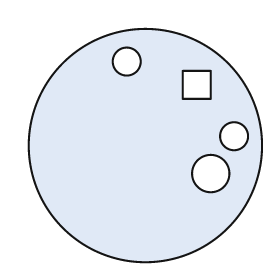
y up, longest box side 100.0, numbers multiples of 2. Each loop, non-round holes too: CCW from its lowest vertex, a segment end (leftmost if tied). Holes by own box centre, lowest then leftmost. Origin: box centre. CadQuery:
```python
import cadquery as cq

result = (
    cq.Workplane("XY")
    .moveTo(0.0, 0.0)
    .circle(50.0)
    .moveTo(28.0, -12.0)
    .circle(8.0)
    .moveTo(38.0, 4.0)
    .circle(6.0)
    .moveTo(16.0, 20.0)
    .lineTo(28.0, 20.0)
    .lineTo(28.0, 32.0)
    .lineTo(16.0, 32.0)
    .close()
    .moveTo(-8.0, 36.0)
    .circle(6.0)
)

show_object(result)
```